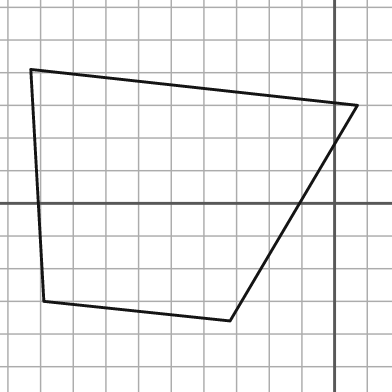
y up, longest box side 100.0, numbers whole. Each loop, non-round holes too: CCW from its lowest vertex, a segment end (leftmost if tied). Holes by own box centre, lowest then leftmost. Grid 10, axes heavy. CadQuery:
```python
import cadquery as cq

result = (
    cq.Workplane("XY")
    .moveTo(-32.0, -36.0)
    .lineTo(7.0, 30.0)
    .lineTo(-93.0, 41.0)
    .lineTo(-89.0, -30.0)
    .close()
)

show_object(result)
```